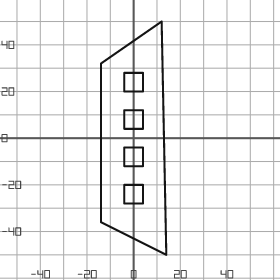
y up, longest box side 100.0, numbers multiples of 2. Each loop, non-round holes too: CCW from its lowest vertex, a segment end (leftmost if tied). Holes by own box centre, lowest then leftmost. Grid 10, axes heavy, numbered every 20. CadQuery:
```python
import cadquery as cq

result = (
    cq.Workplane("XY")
    .moveTo(14.0, -50.0)
    .lineTo(12.0, 50.0)
    .lineTo(-14.0, 32.0)
    .lineTo(-14.0, -36.0)
    .close()
    .moveTo(-4.0, -28.0)
    .lineTo(4.0, -28.0)
    .lineTo(4.0, -20.0)
    .lineTo(-4.0, -20.0)
    .close()
    .moveTo(-4.0, -12.0)
    .lineTo(4.0, -12.0)
    .lineTo(4.0, -4.0)
    .lineTo(-4.0, -4.0)
    .close()
    .moveTo(-4.0, 4.0)
    .lineTo(4.0, 4.0)
    .lineTo(4.0, 12.0)
    .lineTo(-4.0, 12.0)
    .close()
    .moveTo(-4.0, 20.0)
    .lineTo(4.0, 20.0)
    .lineTo(4.0, 28.0)
    .lineTo(-4.0, 28.0)
    .close()
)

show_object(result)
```